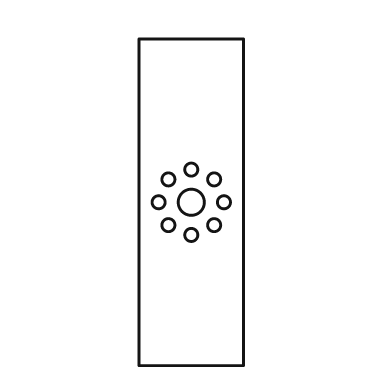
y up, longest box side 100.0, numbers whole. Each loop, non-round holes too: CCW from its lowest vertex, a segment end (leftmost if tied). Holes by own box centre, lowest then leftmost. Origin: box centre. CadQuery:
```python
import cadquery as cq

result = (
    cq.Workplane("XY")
    .moveTo(-16.0, -50.0)
    .lineTo(16.0, -50.0)
    .lineTo(16.0, 50.0)
    .lineTo(-16.0, 50.0)
    .close()
    .moveTo(0.0, -10.0)
    .circle(2.0)
    .moveTo(-7.0, -7.0)
    .circle(2.0)
    .moveTo(7.0, -7.0)
    .circle(2.0)
    .moveTo(-10.0, 0.0)
    .circle(2.0)
    .moveTo(0.0, 0.0)
    .circle(4.0)
    .moveTo(10.0, 0.0)
    .circle(2.0)
    .moveTo(-7.0, 7.0)
    .circle(2.0)
    .moveTo(7.0, 7.0)
    .circle(2.0)
    .moveTo(0.0, 10.0)
    .circle(2.0)
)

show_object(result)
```